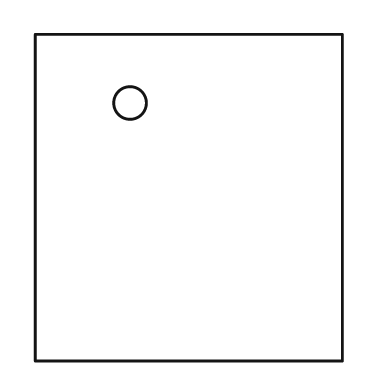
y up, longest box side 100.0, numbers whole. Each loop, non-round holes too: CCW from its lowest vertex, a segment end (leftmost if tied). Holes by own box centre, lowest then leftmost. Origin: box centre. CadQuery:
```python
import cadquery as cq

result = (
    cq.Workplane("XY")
    .moveTo(-47.0, -50.0)
    .lineTo(47.0, -50.0)
    .lineTo(47.0, 50.0)
    .lineTo(-47.0, 50.0)
    .close()
    .moveTo(-18.0, 29.0)
    .circle(5.0)
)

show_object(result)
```